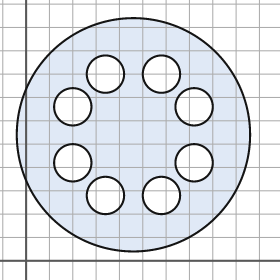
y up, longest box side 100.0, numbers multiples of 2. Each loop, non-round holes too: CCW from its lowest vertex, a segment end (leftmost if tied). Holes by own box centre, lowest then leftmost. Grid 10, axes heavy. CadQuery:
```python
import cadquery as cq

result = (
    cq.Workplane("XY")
    .moveTo(46.0, 54.0)
    .circle(50.0)
    .moveTo(34.0, 28.0)
    .circle(8.0)
    .moveTo(58.0, 28.0)
    .circle(8.0)
    .moveTo(20.0, 42.0)
    .circle(8.0)
    .moveTo(72.0, 42.0)
    .circle(8.0)
    .moveTo(20.0, 66.0)
    .circle(8.0)
    .moveTo(72.0, 66.0)
    .circle(8.0)
    .moveTo(34.0, 80.0)
    .circle(8.0)
    .moveTo(58.0, 80.0)
    .circle(8.0)
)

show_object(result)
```